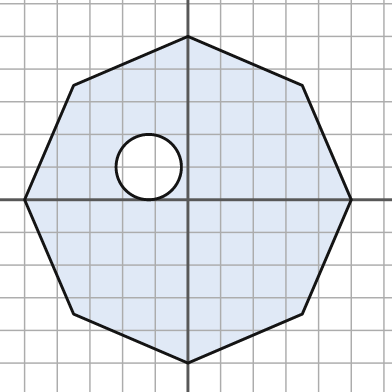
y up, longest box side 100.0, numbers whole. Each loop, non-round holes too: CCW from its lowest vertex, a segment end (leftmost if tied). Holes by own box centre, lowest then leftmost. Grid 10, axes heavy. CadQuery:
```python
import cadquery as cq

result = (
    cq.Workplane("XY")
    .moveTo(0.0, -50.0)
    .lineTo(35.0, -35.0)
    .lineTo(50.0, 0.0)
    .lineTo(35.0, 35.0)
    .lineTo(0.0, 50.0)
    .lineTo(-35.0, 35.0)
    .lineTo(-50.0, 0.0)
    .lineTo(-35.0, -35.0)
    .close()
    .moveTo(-12.0, 10.0)
    .circle(10.0)
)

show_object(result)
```